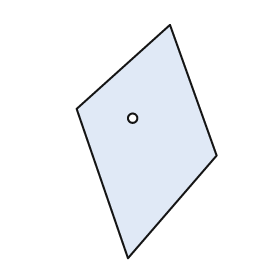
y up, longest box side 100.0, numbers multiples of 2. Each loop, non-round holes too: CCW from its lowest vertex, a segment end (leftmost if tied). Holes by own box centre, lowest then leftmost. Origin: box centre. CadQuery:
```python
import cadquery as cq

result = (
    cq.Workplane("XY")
    .moveTo(-8.0, -50.0)
    .lineTo(30.0, -6.0)
    .lineTo(10.0, 50.0)
    .lineTo(-30.0, 14.0)
    .close()
    .moveTo(-6.0, 10.0)
    .circle(2.0)
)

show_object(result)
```